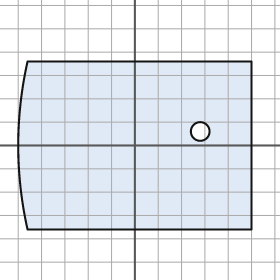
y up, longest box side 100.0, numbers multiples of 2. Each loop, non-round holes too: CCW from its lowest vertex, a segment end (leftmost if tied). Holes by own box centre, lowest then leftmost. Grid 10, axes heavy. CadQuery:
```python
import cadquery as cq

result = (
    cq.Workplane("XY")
    .moveTo(-46.0, -36.0)
    .lineTo(50.0, -36.0)
    .lineTo(50.0, 36.0)
    .lineTo(-46.0, 36.0)
    .threePointArc((-50.0, 0.0), (-46.0, -36.0))
    .close()
    .moveTo(28.0, 6.0)
    .circle(4.0)
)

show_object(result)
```